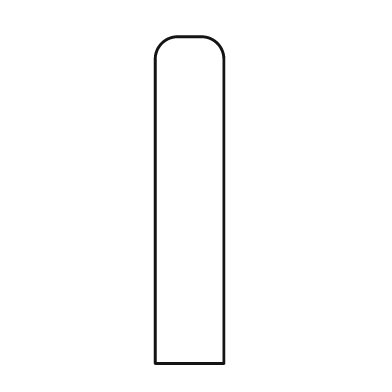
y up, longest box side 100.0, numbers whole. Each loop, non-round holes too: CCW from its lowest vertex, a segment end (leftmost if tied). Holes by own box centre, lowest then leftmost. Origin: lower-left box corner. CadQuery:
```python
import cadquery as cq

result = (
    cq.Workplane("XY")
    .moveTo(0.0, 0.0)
    .lineTo(21.0, 0.0)
    .lineTo(21.0, 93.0)
    .threePointArc((19.0, 98.0), (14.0, 100.0))
    .lineTo(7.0, 100.0)
    .threePointArc((2.0, 98.0), (0.0, 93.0))
    .close()
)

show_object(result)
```